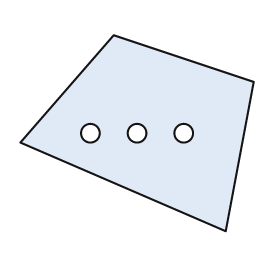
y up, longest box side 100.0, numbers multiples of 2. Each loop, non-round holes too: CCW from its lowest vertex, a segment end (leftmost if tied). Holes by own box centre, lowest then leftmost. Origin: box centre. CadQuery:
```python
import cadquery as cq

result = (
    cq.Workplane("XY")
    .moveTo(38.0, -42.0)
    .lineTo(50.0, 22.0)
    .lineTo(-10.0, 42.0)
    .lineTo(-50.0, -4.0)
    .close()
    .moveTo(-20.0, 0.0)
    .circle(4.0)
    .moveTo(0.0, 0.0)
    .circle(4.0)
    .moveTo(20.0, 0.0)
    .circle(4.0)
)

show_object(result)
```